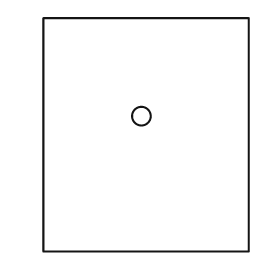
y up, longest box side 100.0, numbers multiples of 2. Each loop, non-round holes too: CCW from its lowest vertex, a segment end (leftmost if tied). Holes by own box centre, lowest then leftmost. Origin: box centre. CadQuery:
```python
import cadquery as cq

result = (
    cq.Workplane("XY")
    .moveTo(-44.0, -50.0)
    .lineTo(44.0, -50.0)
    .lineTo(44.0, 50.0)
    .lineTo(-44.0, 50.0)
    .close()
    .moveTo(-2.0, 8.0)
    .circle(4.0)
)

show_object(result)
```